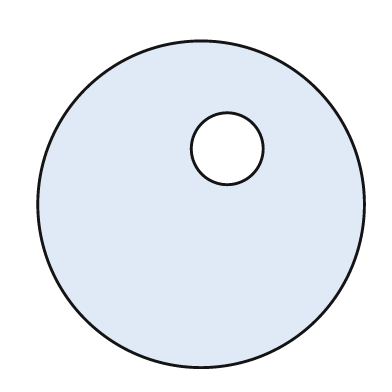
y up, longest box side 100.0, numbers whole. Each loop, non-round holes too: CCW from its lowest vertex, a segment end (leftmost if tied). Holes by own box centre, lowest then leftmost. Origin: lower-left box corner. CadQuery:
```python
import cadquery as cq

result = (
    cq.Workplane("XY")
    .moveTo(50.0, 50.0)
    .circle(50.0)
    .moveTo(58.0, 67.0)
    .circle(11.0)
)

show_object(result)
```